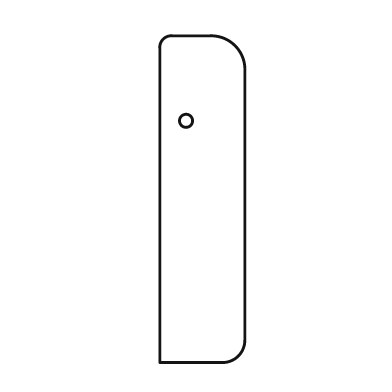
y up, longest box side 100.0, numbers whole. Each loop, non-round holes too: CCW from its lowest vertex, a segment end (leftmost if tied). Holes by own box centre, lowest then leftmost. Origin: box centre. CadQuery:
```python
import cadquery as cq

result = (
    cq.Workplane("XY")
    .moveTo(-13.0, -50.0)
    .lineTo(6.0, -50.0)
    .threePointArc((11.0, -48.0), (13.0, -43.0))
    .lineTo(13.0, 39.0)
    .threePointArc((10.0, 47.0), (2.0, 50.0))
    .lineTo(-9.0, 50.0)
    .threePointArc((-12.0, 49.0), (-13.0, 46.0))
    .close()
    .moveTo(-5.0, 24.0)
    .circle(2.0)
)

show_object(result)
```